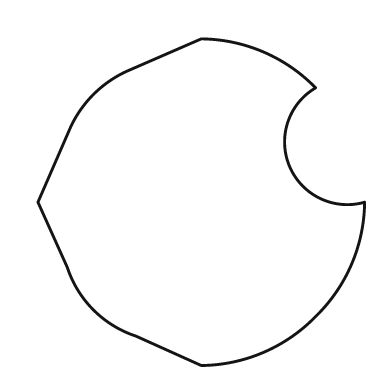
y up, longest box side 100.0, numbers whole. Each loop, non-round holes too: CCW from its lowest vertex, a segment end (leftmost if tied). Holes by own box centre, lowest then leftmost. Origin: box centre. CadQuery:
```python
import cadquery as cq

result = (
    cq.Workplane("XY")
    .moveTo(0.0, -50.0)
    .threePointArc((19.0, -46.0), (35.0, -35.0))
    .threePointArc((46.0, -19.0), (50.0, 0.0))
    .threePointArc((27.0, 11.0), (35.0, 35.0))
    .threePointArc((19.0, 46.0), (0.0, 50.0))
    .lineTo(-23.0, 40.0)
    .threePointArc((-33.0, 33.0), (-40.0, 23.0))
    .lineTo(-50.0, 0.0)
    .lineTo(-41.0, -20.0)
    .threePointArc((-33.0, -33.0), (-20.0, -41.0))
    .close()
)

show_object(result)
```